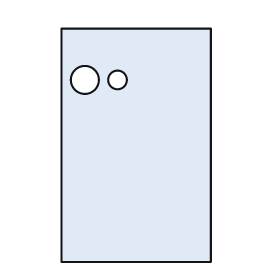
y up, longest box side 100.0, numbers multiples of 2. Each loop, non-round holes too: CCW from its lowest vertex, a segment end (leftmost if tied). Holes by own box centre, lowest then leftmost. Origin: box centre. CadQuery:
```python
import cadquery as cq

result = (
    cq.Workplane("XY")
    .moveTo(-32.0, -50.0)
    .lineTo(32.0, -50.0)
    .lineTo(32.0, 50.0)
    .lineTo(-32.0, 50.0)
    .close()
    .moveTo(-22.0, 28.0)
    .circle(6.0)
    .moveTo(-8.0, 28.0)
    .circle(4.0)
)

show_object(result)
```